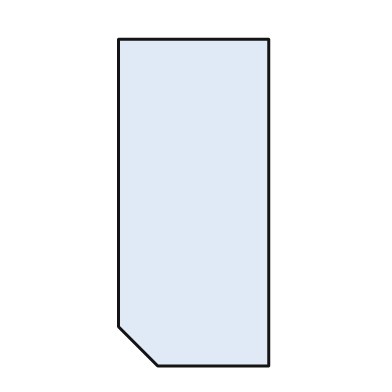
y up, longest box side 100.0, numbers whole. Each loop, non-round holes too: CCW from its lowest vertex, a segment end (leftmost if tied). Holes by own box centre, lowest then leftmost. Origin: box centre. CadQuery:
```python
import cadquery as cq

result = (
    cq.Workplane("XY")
    .moveTo(-11.0, -50.0)
    .lineTo(23.0, -50.0)
    .lineTo(23.0, 50.0)
    .lineTo(-23.0, 50.0)
    .lineTo(-23.0, -38.0)
    .close()
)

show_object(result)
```